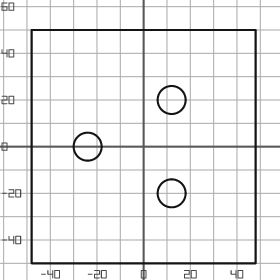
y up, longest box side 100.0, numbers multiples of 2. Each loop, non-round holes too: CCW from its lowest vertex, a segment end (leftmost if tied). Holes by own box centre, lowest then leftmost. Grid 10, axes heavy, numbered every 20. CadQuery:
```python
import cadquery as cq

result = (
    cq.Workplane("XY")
    .moveTo(-48.0, -50.0)
    .lineTo(48.0, -50.0)
    .lineTo(48.0, 50.0)
    .lineTo(-48.0, 50.0)
    .close()
    .moveTo(12.0, -20.0)
    .circle(6.0)
    .moveTo(-24.0, 0.0)
    .circle(6.0)
    .moveTo(12.0, 20.0)
    .circle(6.0)
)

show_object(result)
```